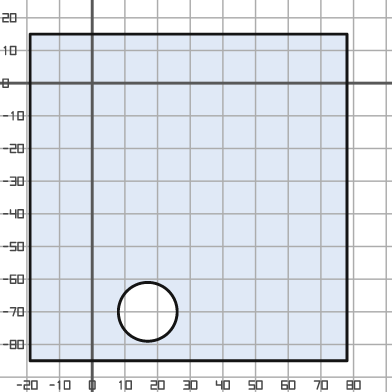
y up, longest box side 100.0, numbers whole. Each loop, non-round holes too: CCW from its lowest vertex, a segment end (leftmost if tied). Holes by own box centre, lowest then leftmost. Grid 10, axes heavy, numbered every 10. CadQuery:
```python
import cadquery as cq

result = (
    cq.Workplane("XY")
    .moveTo(-19.0, -85.0)
    .lineTo(78.0, -85.0)
    .lineTo(78.0, 15.0)
    .lineTo(-19.0, 15.0)
    .close()
    .moveTo(17.0, -70.0)
    .circle(9.0)
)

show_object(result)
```